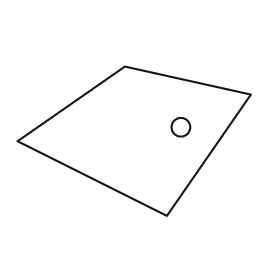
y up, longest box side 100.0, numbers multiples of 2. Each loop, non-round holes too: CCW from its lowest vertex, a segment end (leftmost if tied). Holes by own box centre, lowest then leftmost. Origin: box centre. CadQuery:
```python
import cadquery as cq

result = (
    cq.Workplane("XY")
    .moveTo(14.0, -32.0)
    .lineTo(50.0, 20.0)
    .lineTo(-4.0, 32.0)
    .lineTo(-50.0, 0.0)
    .close()
    .moveTo(20.0, 6.0)
    .circle(4.0)
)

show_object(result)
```